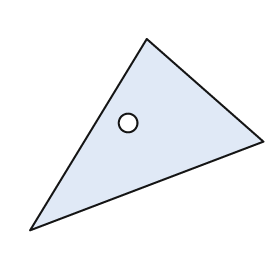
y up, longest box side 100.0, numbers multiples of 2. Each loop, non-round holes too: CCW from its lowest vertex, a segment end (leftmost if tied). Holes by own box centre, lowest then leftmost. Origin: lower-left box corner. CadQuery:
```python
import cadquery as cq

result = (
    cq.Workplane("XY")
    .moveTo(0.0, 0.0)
    .lineTo(100.0, 38.0)
    .lineTo(50.0, 82.0)
    .close()
    .moveTo(42.0, 46.0)
    .circle(4.0)
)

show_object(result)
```